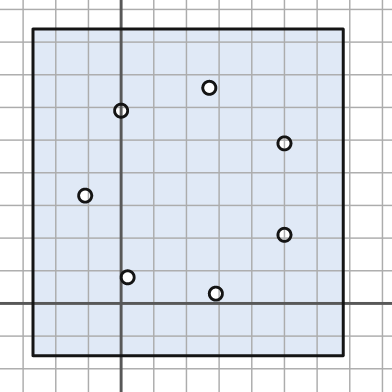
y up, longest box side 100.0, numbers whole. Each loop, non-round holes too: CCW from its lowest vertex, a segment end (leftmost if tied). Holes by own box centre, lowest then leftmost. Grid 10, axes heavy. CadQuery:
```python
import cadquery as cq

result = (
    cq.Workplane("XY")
    .moveTo(-27.0, -16.0)
    .lineTo(68.0, -16.0)
    .lineTo(68.0, 84.0)
    .lineTo(-27.0, 84.0)
    .close()
    .moveTo(29.0, 3.0)
    .circle(2.0)
    .moveTo(2.0, 8.0)
    .circle(2.0)
    .moveTo(50.0, 21.0)
    .circle(2.0)
    .moveTo(-11.0, 33.0)
    .circle(2.0)
    .moveTo(50.0, 49.0)
    .circle(2.0)
    .moveTo(0.0, 59.0)
    .circle(2.0)
    .moveTo(27.0, 66.0)
    .circle(2.0)
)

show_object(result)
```